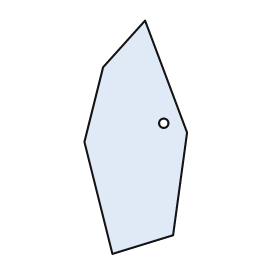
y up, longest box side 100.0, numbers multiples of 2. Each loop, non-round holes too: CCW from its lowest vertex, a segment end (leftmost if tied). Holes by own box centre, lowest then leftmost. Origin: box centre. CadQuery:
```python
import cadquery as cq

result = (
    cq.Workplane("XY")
    .moveTo(-10.0, -50.0)
    .lineTo(16.0, -42.0)
    .lineTo(22.0, 2.0)
    .lineTo(4.0, 50.0)
    .lineTo(-14.0, 30.0)
    .lineTo(-22.0, -2.0)
    .close()
    .moveTo(12.0, 6.0)
    .circle(2.0)
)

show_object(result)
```